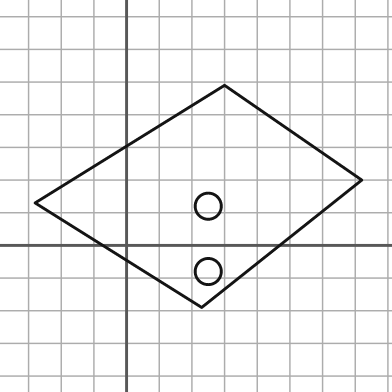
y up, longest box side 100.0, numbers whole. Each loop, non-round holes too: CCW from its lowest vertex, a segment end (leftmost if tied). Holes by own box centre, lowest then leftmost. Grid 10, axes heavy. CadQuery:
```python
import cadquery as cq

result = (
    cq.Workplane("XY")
    .moveTo(23.0, -19.0)
    .lineTo(72.0, 20.0)
    .lineTo(30.0, 49.0)
    .lineTo(-28.0, 13.0)
    .close()
    .moveTo(25.0, -8.0)
    .circle(4.0)
    .moveTo(25.0, 12.0)
    .circle(4.0)
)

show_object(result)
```